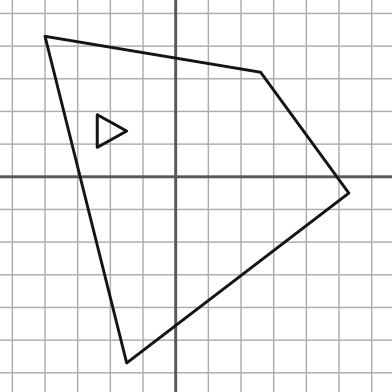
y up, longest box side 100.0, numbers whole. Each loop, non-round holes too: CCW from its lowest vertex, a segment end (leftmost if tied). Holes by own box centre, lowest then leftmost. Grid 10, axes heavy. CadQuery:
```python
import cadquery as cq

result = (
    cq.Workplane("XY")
    .moveTo(-15.0, -57.0)
    .lineTo(53.0, -5.0)
    .lineTo(26.0, 32.0)
    .lineTo(-40.0, 43.0)
    .close()
    .moveTo(-24.0, 9.0)
    .lineTo(-15.0, 14.0)
    .lineTo(-24.0, 19.0)
    .close()
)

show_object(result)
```